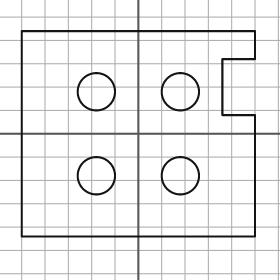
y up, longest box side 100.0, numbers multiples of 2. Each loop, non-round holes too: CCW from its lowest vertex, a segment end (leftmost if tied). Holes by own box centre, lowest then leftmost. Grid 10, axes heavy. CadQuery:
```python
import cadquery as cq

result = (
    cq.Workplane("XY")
    .moveTo(-50.0, -44.0)
    .lineTo(50.0, -44.0)
    .lineTo(50.0, 8.0)
    .lineTo(36.0, 8.0)
    .lineTo(36.0, 32.0)
    .lineTo(50.0, 32.0)
    .lineTo(50.0, 44.0)
    .lineTo(-50.0, 44.0)
    .close()
    .moveTo(-18.0, -18.0)
    .circle(8.0)
    .moveTo(18.0, -18.0)
    .circle(8.0)
    .moveTo(-18.0, 18.0)
    .circle(8.0)
    .moveTo(18.0, 18.0)
    .circle(8.0)
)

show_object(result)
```